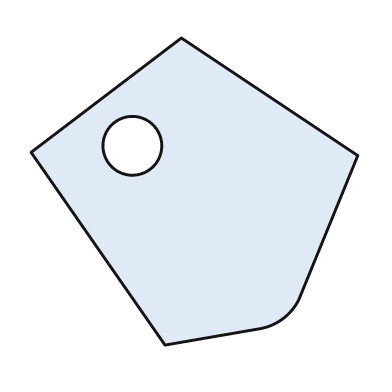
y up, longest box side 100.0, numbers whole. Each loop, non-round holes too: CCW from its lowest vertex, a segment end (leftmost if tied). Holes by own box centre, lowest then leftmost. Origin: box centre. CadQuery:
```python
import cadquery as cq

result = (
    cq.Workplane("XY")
    .moveTo(-9.0, -47.0)
    .lineTo(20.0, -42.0)
    .threePointArc((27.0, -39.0), (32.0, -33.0))
    .lineTo(50.0, 11.0)
    .lineTo(-4.0, 47.0)
    .lineTo(-50.0, 12.0)
    .close()
    .moveTo(-19.0, 14.0)
    .circle(9.0)
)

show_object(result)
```